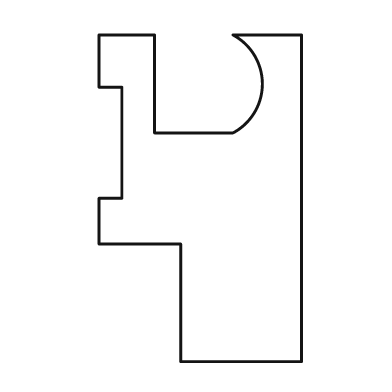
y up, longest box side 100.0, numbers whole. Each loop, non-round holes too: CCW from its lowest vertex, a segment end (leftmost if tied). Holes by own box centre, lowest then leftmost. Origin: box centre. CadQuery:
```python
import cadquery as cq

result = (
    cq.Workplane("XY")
    .moveTo(-6.0, -50.0)
    .lineTo(31.0, -50.0)
    .lineTo(31.0, 50.0)
    .lineTo(10.0, 50.0)
    .threePointArc((19.0, 35.0), (10.0, 20.0))
    .lineTo(-14.0, 20.0)
    .lineTo(-14.0, 50.0)
    .lineTo(-31.0, 50.0)
    .lineTo(-31.0, 34.0)
    .lineTo(-24.0, 34.0)
    .lineTo(-24.0, 0.0)
    .lineTo(-31.0, 0.0)
    .lineTo(-31.0, -14.0)
    .lineTo(-6.0, -14.0)
    .close()
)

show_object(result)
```